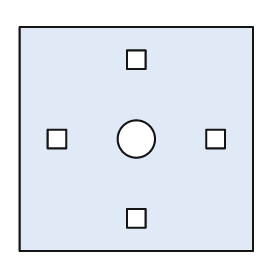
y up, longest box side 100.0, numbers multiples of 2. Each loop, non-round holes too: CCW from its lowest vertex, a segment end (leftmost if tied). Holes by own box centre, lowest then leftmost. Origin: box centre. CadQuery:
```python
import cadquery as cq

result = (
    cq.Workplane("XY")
    .moveTo(-50.0, -48.0)
    .lineTo(50.0, -48.0)
    .lineTo(50.0, 48.0)
    .lineTo(-50.0, 48.0)
    .close()
    .moveTo(-4.0, -38.0)
    .lineTo(4.0, -38.0)
    .lineTo(4.0, -30.0)
    .lineTo(-4.0, -30.0)
    .close()
    .moveTo(-38.0, -4.0)
    .lineTo(-30.0, -4.0)
    .lineTo(-30.0, 4.0)
    .lineTo(-38.0, 4.0)
    .close()
    .moveTo(0.0, 0.0)
    .circle(8.0)
    .moveTo(30.0, -4.0)
    .lineTo(38.0, -4.0)
    .lineTo(38.0, 4.0)
    .lineTo(30.0, 4.0)
    .close()
    .moveTo(-4.0, 30.0)
    .lineTo(4.0, 30.0)
    .lineTo(4.0, 38.0)
    .lineTo(-4.0, 38.0)
    .close()
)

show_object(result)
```